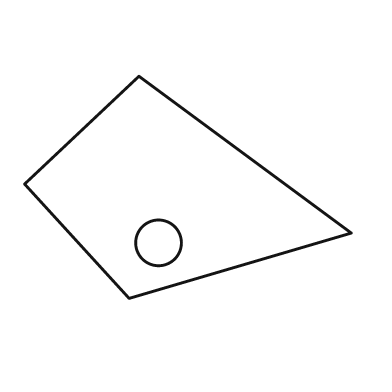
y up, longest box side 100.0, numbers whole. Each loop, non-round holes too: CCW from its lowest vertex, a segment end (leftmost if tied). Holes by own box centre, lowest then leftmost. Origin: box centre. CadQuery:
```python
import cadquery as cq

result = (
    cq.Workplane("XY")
    .moveTo(-18.0, -34.0)
    .lineTo(50.0, -14.0)
    .lineTo(-15.0, 34.0)
    .lineTo(-50.0, 1.0)
    .close()
    .moveTo(-9.0, -17.0)
    .circle(7.0)
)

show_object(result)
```